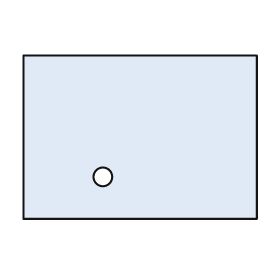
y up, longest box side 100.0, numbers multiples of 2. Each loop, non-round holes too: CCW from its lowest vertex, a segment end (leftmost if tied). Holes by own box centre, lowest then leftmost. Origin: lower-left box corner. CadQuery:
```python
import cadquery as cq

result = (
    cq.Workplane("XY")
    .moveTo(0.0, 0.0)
    .lineTo(100.0, 0.0)
    .lineTo(100.0, 70.0)
    .lineTo(0.0, 70.0)
    .close()
    .moveTo(34.0, 18.0)
    .circle(4.0)
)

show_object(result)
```